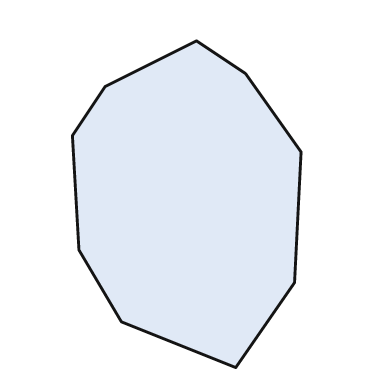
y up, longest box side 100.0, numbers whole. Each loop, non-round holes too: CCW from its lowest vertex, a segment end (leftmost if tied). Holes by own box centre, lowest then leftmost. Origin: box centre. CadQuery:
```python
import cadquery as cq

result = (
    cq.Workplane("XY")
    .moveTo(15.0, -50.0)
    .lineTo(33.0, -24.0)
    .lineTo(35.0, 16.0)
    .lineTo(18.0, 40.0)
    .lineTo(3.0, 50.0)
    .lineTo(-25.0, 36.0)
    .lineTo(-35.0, 21.0)
    .lineTo(-33.0, -14.0)
    .lineTo(-20.0, -36.0)
    .close()
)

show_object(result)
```